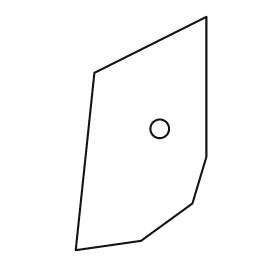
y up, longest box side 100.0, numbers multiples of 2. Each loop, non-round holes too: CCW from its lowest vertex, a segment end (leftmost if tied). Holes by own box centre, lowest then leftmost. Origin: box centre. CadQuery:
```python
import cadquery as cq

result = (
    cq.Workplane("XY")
    .moveTo(-28.0, -50.0)
    .lineTo(0.0, -46.0)
    .lineTo(22.0, -30.0)
    .lineTo(28.0, -10.0)
    .lineTo(28.0, 50.0)
    .lineTo(-20.0, 26.0)
    .close()
    .moveTo(8.0, 2.0)
    .circle(4.0)
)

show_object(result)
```